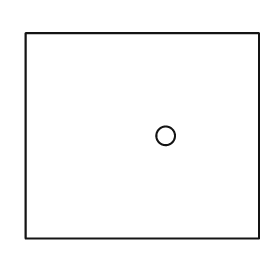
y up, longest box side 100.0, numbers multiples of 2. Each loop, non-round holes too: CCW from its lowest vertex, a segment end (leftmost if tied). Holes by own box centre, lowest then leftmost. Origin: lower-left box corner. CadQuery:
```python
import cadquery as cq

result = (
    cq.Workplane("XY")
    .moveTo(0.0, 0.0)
    .lineTo(100.0, 0.0)
    .lineTo(100.0, 88.0)
    .lineTo(0.0, 88.0)
    .close()
    .moveTo(60.0, 44.0)
    .circle(4.0)
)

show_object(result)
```